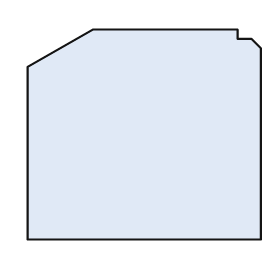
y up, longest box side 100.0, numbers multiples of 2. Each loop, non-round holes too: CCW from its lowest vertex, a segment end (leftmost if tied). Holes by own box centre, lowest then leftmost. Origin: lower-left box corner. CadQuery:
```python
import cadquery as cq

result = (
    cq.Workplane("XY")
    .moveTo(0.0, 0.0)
    .lineTo(100.0, 0.0)
    .lineTo(100.0, 82.0)
    .lineTo(96.0, 86.0)
    .lineTo(90.0, 86.0)
    .lineTo(90.0, 90.0)
    .lineTo(28.0, 90.0)
    .lineTo(0.0, 74.0)
    .close()
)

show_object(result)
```